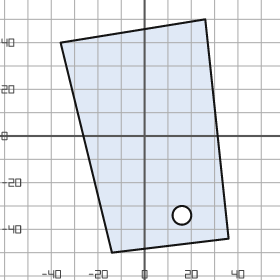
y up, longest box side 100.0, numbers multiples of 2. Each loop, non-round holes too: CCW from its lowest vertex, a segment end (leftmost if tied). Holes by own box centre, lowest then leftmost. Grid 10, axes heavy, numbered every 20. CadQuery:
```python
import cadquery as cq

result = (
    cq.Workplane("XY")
    .moveTo(-14.0, -50.0)
    .lineTo(36.0, -44.0)
    .lineTo(26.0, 50.0)
    .lineTo(-36.0, 40.0)
    .close()
    .moveTo(16.0, -34.0)
    .circle(4.0)
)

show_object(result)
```